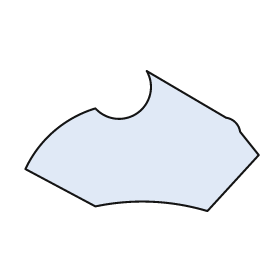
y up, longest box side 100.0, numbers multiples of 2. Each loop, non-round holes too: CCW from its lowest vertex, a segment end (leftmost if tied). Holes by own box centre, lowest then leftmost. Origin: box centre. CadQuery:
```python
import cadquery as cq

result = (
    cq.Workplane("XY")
    .moveTo(28.0, -30.0)
    .lineTo(50.0, -6.0)
    .lineTo(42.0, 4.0)
    .threePointArc((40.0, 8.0), (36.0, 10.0))
    .lineTo(2.0, 30.0)
    .threePointArc((-2.0, 12.0), (-20.0, 14.0))
    .threePointArc((-38.0, 4.0), (-50.0, -12.0))
    .lineTo(-20.0, -28.0)
    .threePointArc((4.0, -26.0), (28.0, -30.0))
    .close()
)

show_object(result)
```